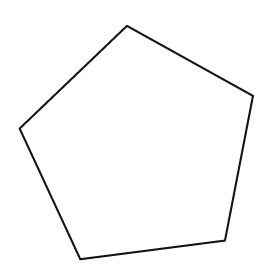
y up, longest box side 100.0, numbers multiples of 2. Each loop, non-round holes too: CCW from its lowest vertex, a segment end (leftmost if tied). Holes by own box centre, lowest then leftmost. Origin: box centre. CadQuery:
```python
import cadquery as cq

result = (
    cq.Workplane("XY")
    .moveTo(-24.0, -50.0)
    .lineTo(38.0, -42.0)
    .lineTo(50.0, 20.0)
    .lineTo(-4.0, 50.0)
    .lineTo(-50.0, 6.0)
    .close()
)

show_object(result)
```